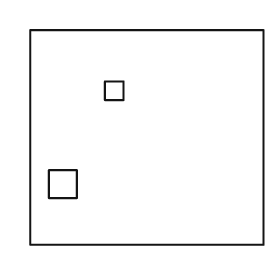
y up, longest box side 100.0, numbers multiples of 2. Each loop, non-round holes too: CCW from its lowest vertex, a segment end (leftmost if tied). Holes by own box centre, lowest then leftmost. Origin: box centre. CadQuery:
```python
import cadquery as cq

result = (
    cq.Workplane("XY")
    .moveTo(-50.0, -46.0)
    .lineTo(50.0, -46.0)
    .lineTo(50.0, 46.0)
    .lineTo(-50.0, 46.0)
    .close()
    .moveTo(-42.0, -26.0)
    .lineTo(-30.0, -26.0)
    .lineTo(-30.0, -14.0)
    .lineTo(-42.0, -14.0)
    .close()
    .moveTo(-18.0, 16.0)
    .lineTo(-10.0, 16.0)
    .lineTo(-10.0, 24.0)
    .lineTo(-18.0, 24.0)
    .close()
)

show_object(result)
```